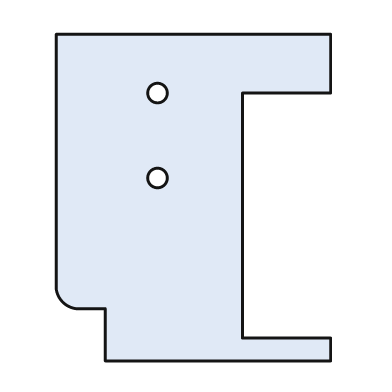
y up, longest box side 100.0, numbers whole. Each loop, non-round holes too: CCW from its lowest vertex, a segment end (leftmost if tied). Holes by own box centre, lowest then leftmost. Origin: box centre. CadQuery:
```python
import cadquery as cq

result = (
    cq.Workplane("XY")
    .moveTo(-27.0, -50.0)
    .lineTo(42.0, -50.0)
    .lineTo(42.0, -43.0)
    .lineTo(15.0, -43.0)
    .lineTo(15.0, 32.0)
    .lineTo(42.0, 32.0)
    .lineTo(42.0, 50.0)
    .lineTo(-42.0, 50.0)
    .lineTo(-42.0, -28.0)
    .threePointArc((-40.0, -32.0), (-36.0, -34.0))
    .lineTo(-27.0, -34.0)
    .close()
    .moveTo(-11.0, 6.0)
    .circle(3.0)
    .moveTo(-11.0, 32.0)
    .circle(3.0)
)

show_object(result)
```